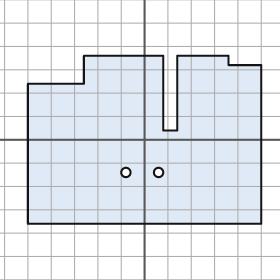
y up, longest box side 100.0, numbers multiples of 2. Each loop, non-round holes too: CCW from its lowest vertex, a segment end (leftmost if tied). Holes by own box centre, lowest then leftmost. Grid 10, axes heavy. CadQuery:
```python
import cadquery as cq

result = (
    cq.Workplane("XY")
    .moveTo(-50.0, -36.0)
    .lineTo(50.0, -36.0)
    .lineTo(50.0, 32.0)
    .lineTo(36.0, 32.0)
    .lineTo(36.0, 36.0)
    .lineTo(14.0, 36.0)
    .lineTo(14.0, 4.0)
    .lineTo(8.0, 4.0)
    .lineTo(8.0, 36.0)
    .lineTo(-26.0, 36.0)
    .lineTo(-26.0, 24.0)
    .lineTo(-50.0, 24.0)
    .close()
    .moveTo(-8.0, -14.0)
    .circle(2.0)
    .moveTo(6.0, -14.0)
    .circle(2.0)
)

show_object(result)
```